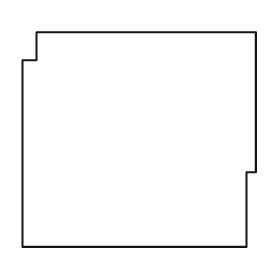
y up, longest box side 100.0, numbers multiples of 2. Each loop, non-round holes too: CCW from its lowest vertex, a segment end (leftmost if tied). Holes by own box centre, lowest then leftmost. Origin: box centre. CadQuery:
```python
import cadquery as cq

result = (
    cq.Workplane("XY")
    .moveTo(-50.0, -46.0)
    .lineTo(46.0, -46.0)
    .lineTo(46.0, -14.0)
    .lineTo(50.0, -14.0)
    .lineTo(50.0, 46.0)
    .lineTo(-44.0, 46.0)
    .lineTo(-44.0, 34.0)
    .lineTo(-50.0, 34.0)
    .close()
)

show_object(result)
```